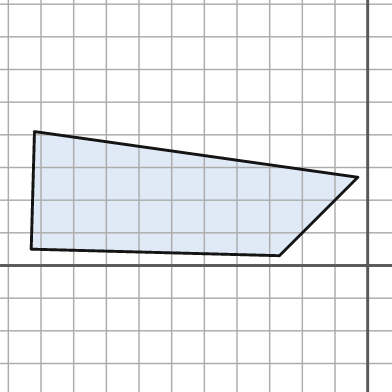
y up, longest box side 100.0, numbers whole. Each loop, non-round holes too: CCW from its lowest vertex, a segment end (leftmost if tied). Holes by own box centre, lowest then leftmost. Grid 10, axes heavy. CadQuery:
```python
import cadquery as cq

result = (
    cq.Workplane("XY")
    .moveTo(-27.0, 3.0)
    .lineTo(-3.0, 27.0)
    .lineTo(-102.0, 41.0)
    .lineTo(-103.0, 5.0)
    .close()
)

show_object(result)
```